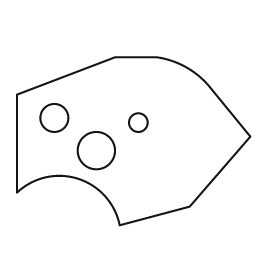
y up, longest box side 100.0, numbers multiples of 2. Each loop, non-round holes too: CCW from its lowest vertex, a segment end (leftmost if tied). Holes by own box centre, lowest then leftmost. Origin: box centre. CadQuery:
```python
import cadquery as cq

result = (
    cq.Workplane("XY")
    .moveTo(-6.0, -36.0)
    .lineTo(24.0, -28.0)
    .lineTo(50.0, 2.0)
    .lineTo(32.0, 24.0)
    .threePointArc((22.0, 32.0), (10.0, 36.0))
    .lineTo(-8.0, 36.0)
    .lineTo(-50.0, 20.0)
    .lineTo(-50.0, -22.0)
    .threePointArc((-24.0, -16.0), (-6.0, -36.0))
    .close()
    .moveTo(-16.0, -4.0)
    .circle(8.0)
    .moveTo(2.0, 8.0)
    .circle(4.0)
    .moveTo(-34.0, 10.0)
    .circle(6.0)
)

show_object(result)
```